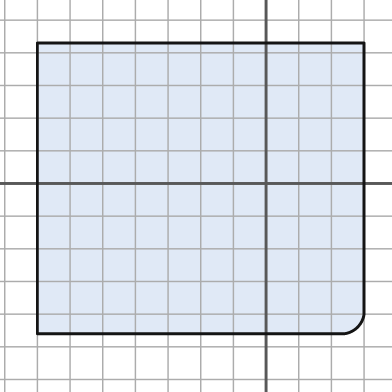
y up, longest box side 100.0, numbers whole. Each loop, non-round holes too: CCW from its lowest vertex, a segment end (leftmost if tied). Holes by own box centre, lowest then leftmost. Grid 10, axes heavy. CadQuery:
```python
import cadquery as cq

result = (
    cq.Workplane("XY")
    .moveTo(-70.0, -46.0)
    .lineTo(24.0, -46.0)
    .threePointArc((28.0, -44.0), (30.0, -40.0))
    .lineTo(30.0, 43.0)
    .lineTo(-70.0, 43.0)
    .close()
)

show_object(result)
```